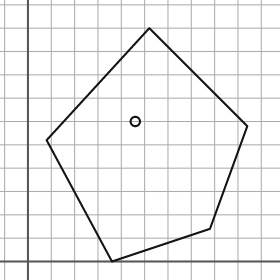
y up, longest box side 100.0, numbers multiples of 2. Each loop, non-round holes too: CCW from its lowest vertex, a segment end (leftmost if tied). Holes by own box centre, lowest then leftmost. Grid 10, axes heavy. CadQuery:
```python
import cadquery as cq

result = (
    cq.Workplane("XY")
    .moveTo(36.0, 0.0)
    .lineTo(78.0, 14.0)
    .lineTo(94.0, 58.0)
    .lineTo(52.0, 100.0)
    .lineTo(8.0, 52.0)
    .close()
    .moveTo(46.0, 60.0)
    .circle(2.0)
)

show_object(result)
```